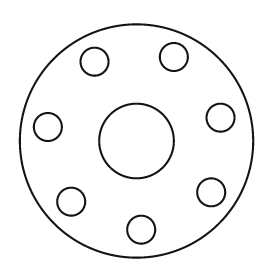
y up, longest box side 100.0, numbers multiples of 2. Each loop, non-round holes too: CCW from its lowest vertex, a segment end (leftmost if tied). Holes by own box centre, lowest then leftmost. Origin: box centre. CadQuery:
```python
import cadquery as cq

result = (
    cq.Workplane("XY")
    .moveTo(0.0, 0.0)
    .circle(50.0)
    .moveTo(2.0, -38.0)
    .circle(6.0)
    .moveTo(-28.0, -26.0)
    .circle(6.0)
    .moveTo(32.0, -22.0)
    .circle(6.0)
    .moveTo(0.0, 0.0)
    .circle(16.0)
    .moveTo(-38.0, 6.0)
    .circle(6.0)
    .moveTo(36.0, 10.0)
    .circle(6.0)
    .moveTo(-18.0, 34.0)
    .circle(6.0)
    .moveTo(16.0, 36.0)
    .circle(6.0)
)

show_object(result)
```